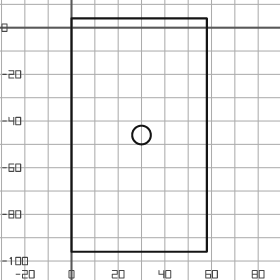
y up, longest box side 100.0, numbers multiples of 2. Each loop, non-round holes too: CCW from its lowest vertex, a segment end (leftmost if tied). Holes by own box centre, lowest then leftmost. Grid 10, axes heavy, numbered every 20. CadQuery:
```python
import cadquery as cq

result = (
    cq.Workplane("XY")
    .moveTo(0.0, -96.0)
    .lineTo(58.0, -96.0)
    .lineTo(58.0, 4.0)
    .lineTo(0.0, 4.0)
    .close()
    .moveTo(30.0, -46.0)
    .circle(4.0)
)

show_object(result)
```